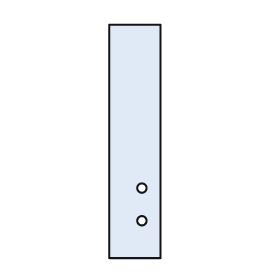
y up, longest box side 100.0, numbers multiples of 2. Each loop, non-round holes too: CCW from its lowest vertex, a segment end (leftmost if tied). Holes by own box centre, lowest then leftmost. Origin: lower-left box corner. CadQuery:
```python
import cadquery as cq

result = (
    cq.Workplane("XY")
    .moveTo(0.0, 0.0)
    .lineTo(22.0, 0.0)
    .lineTo(22.0, 100.0)
    .lineTo(0.0, 100.0)
    .close()
    .moveTo(14.0, 16.0)
    .circle(2.0)
    .moveTo(14.0, 30.0)
    .circle(2.0)
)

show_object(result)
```